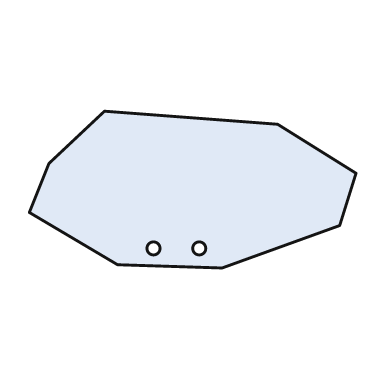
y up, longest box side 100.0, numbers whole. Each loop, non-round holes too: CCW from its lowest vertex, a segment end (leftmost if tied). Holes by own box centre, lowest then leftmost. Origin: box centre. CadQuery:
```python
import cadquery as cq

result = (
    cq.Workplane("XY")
    .moveTo(9.0, -24.0)
    .lineTo(45.0, -11.0)
    .lineTo(50.0, 5.0)
    .lineTo(26.0, 20.0)
    .lineTo(-27.0, 24.0)
    .lineTo(-44.0, 8.0)
    .lineTo(-50.0, -7.0)
    .lineTo(-23.0, -23.0)
    .close()
    .moveTo(-12.0, -18.0)
    .circle(2.0)
    .moveTo(2.0, -18.0)
    .circle(2.0)
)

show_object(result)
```